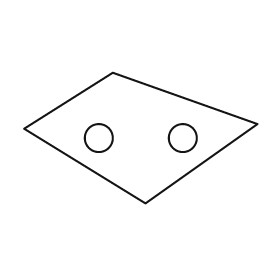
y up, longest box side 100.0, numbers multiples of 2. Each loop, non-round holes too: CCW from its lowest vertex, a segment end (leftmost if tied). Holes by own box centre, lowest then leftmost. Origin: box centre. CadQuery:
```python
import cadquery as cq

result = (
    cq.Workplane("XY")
    .moveTo(2.0, -28.0)
    .lineTo(50.0, 6.0)
    .lineTo(-12.0, 28.0)
    .lineTo(-50.0, 4.0)
    .close()
    .moveTo(-18.0, 0.0)
    .circle(6.0)
    .moveTo(18.0, 0.0)
    .circle(6.0)
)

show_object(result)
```